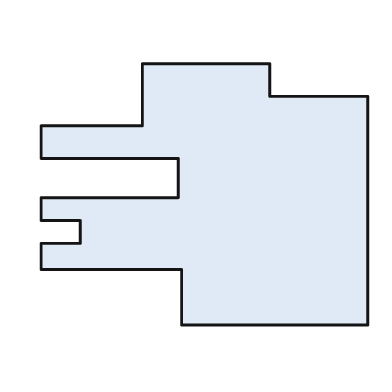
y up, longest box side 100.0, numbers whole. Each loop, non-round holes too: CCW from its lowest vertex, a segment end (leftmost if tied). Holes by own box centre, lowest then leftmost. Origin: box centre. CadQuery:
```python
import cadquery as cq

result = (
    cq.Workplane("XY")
    .moveTo(-7.0, -40.0)
    .lineTo(50.0, -40.0)
    .lineTo(50.0, 30.0)
    .lineTo(20.0, 30.0)
    .lineTo(20.0, 40.0)
    .lineTo(-19.0, 40.0)
    .lineTo(-19.0, 21.0)
    .lineTo(-50.0, 21.0)
    .lineTo(-50.0, 11.0)
    .lineTo(-8.0, 11.0)
    .lineTo(-8.0, -1.0)
    .lineTo(-50.0, -1.0)
    .lineTo(-50.0, -8.0)
    .lineTo(-38.0, -8.0)
    .lineTo(-38.0, -15.0)
    .lineTo(-50.0, -15.0)
    .lineTo(-50.0, -23.0)
    .lineTo(-7.0, -23.0)
    .close()
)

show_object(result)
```